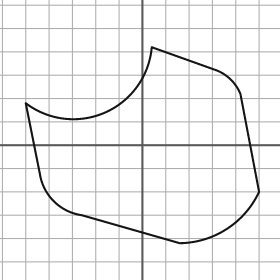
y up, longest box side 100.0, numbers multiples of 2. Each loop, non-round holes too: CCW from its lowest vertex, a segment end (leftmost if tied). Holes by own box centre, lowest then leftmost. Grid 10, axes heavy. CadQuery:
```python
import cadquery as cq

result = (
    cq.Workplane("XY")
    .moveTo(16.0, -42.0)
    .threePointArc((36.0, -36.0), (50.0, -20.0))
    .lineTo(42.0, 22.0)
    .threePointArc((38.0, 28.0), (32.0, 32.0))
    .lineTo(4.0, 42.0)
    .threePointArc((-16.0, 14.0), (-50.0, 18.0))
    .lineTo(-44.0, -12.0)
    .threePointArc((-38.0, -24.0), (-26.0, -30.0))
    .close()
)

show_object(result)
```